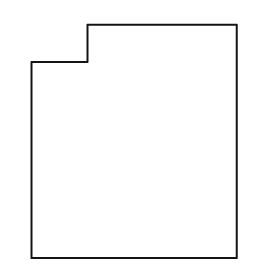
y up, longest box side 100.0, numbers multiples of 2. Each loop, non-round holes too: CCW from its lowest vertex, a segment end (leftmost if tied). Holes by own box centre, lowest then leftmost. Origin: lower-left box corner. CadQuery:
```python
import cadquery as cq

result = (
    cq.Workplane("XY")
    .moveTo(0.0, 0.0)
    .lineTo(88.0, 0.0)
    .lineTo(88.0, 100.0)
    .lineTo(24.0, 100.0)
    .lineTo(24.0, 84.0)
    .lineTo(0.0, 84.0)
    .close()
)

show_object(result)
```